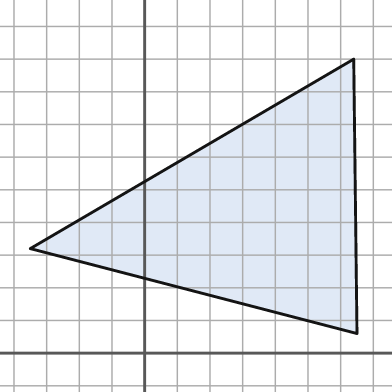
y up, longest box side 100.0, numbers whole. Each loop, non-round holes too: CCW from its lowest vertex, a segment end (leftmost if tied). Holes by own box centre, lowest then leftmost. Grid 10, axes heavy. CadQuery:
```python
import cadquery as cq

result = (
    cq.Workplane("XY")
    .moveTo(65.0, 6.0)
    .lineTo(64.0, 90.0)
    .lineTo(-35.0, 32.0)
    .close()
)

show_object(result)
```